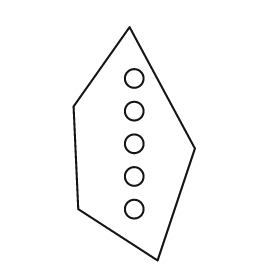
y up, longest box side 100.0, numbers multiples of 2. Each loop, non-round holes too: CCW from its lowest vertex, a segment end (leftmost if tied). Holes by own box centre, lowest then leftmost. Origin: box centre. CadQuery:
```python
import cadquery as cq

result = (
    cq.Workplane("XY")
    .moveTo(10.0, -50.0)
    .lineTo(26.0, -2.0)
    .lineTo(-2.0, 50.0)
    .lineTo(-26.0, 16.0)
    .lineTo(-24.0, -28.0)
    .close()
    .moveTo(0.0, -28.0)
    .circle(4.0)
    .moveTo(0.0, -14.0)
    .circle(4.0)
    .moveTo(0.0, 0.0)
    .circle(4.0)
    .moveTo(0.0, 14.0)
    .circle(4.0)
    .moveTo(0.0, 28.0)
    .circle(4.0)
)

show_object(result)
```